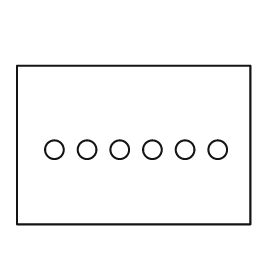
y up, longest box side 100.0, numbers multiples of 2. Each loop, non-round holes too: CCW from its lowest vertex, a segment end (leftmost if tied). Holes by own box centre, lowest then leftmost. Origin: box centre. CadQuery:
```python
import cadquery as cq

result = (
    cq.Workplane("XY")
    .moveTo(-50.0, -34.0)
    .lineTo(50.0, -34.0)
    .lineTo(50.0, 34.0)
    .lineTo(-50.0, 34.0)
    .close()
    .moveTo(-34.0, -2.0)
    .circle(4.0)
    .moveTo(-20.0, -2.0)
    .circle(4.0)
    .moveTo(-6.0, -2.0)
    .circle(4.0)
    .moveTo(8.0, -2.0)
    .circle(4.0)
    .moveTo(22.0, -2.0)
    .circle(4.0)
    .moveTo(36.0, -2.0)
    .circle(4.0)
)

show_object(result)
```